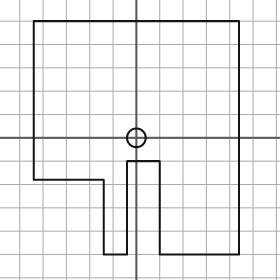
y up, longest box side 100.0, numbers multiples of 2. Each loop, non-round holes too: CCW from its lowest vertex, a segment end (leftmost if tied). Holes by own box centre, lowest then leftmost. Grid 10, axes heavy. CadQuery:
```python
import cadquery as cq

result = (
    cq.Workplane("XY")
    .moveTo(-14.0, -50.0)
    .lineTo(-4.0, -50.0)
    .lineTo(-4.0, -10.0)
    .lineTo(10.0, -10.0)
    .lineTo(10.0, -50.0)
    .lineTo(44.0, -50.0)
    .lineTo(44.0, 50.0)
    .lineTo(-44.0, 50.0)
    .lineTo(-44.0, -18.0)
    .lineTo(-14.0, -18.0)
    .close()
    .moveTo(0.0, 0.0)
    .circle(4.0)
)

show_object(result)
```